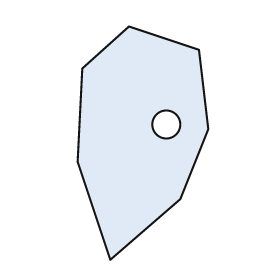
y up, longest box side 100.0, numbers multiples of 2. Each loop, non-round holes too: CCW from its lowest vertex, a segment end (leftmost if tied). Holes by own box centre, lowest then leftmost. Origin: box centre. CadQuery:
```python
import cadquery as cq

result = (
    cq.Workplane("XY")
    .moveTo(-14.0, -50.0)
    .lineTo(16.0, -24.0)
    .lineTo(28.0, 6.0)
    .lineTo(24.0, 40.0)
    .lineTo(-6.0, 50.0)
    .lineTo(-26.0, 32.0)
    .lineTo(-28.0, -8.0)
    .close()
    .moveTo(10.0, 8.0)
    .circle(6.0)
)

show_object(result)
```